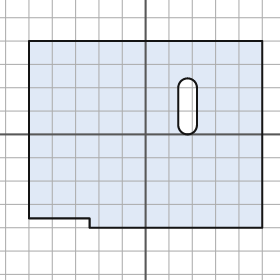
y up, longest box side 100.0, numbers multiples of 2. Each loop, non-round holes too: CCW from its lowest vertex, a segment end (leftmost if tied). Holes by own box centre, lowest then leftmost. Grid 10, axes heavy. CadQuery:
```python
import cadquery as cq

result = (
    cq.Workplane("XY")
    .moveTo(-24.0, -40.0)
    .lineTo(50.0, -40.0)
    .lineTo(50.0, 40.0)
    .lineTo(-50.0, 40.0)
    .lineTo(-50.0, -36.0)
    .lineTo(-24.0, -36.0)
    .close()
    .moveTo(14.0, 4.0)
    .threePointArc((18.0, 0.0), (22.0, 4.0))
    .lineTo(22.0, 20.0)
    .threePointArc((18.0, 24.0), (14.0, 20.0))
    .close()
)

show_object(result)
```